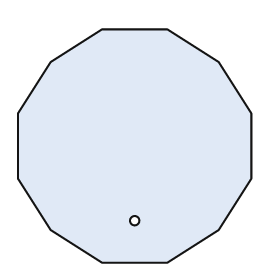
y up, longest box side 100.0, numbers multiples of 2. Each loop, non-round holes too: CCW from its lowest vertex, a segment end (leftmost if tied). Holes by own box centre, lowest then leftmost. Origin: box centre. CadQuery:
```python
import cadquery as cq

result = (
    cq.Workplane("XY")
    .moveTo(-14.0, -50.0)
    .lineTo(14.0, -50.0)
    .lineTo(36.0, -36.0)
    .lineTo(50.0, -14.0)
    .lineTo(50.0, 14.0)
    .lineTo(36.0, 36.0)
    .lineTo(14.0, 50.0)
    .lineTo(-14.0, 50.0)
    .lineTo(-36.0, 36.0)
    .lineTo(-50.0, 14.0)
    .lineTo(-50.0, -14.0)
    .lineTo(-36.0, -36.0)
    .close()
    .moveTo(0.0, -32.0)
    .circle(2.0)
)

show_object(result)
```